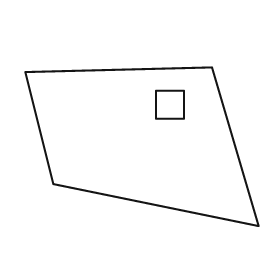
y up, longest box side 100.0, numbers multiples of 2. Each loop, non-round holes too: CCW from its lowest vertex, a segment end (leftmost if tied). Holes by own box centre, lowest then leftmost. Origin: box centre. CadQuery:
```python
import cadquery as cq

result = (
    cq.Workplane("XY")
    .moveTo(50.0, -34.0)
    .lineTo(30.0, 34.0)
    .lineTo(-50.0, 32.0)
    .lineTo(-38.0, -16.0)
    .close()
    .moveTo(6.0, 12.0)
    .lineTo(18.0, 12.0)
    .lineTo(18.0, 24.0)
    .lineTo(6.0, 24.0)
    .close()
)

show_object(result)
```